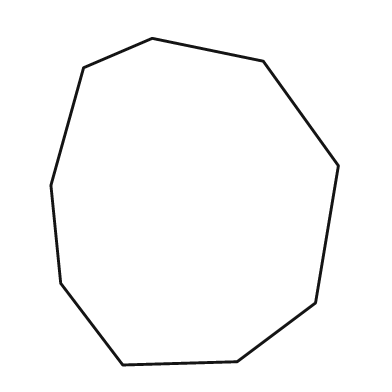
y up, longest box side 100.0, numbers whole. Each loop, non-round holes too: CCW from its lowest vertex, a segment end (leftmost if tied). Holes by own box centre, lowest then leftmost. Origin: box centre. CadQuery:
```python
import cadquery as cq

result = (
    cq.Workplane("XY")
    .moveTo(-22.0, -50.0)
    .lineTo(13.0, -49.0)
    .lineTo(37.0, -31.0)
    .lineTo(44.0, 11.0)
    .lineTo(21.0, 43.0)
    .lineTo(-13.0, 50.0)
    .lineTo(-34.0, 41.0)
    .lineTo(-44.0, 5.0)
    .lineTo(-41.0, -25.0)
    .close()
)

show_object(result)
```